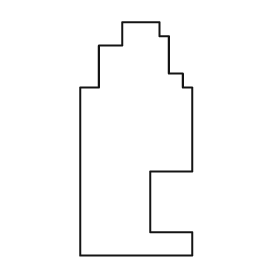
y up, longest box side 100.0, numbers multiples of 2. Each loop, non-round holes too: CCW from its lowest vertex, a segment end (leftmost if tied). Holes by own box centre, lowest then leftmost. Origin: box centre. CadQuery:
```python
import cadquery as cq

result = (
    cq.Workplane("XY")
    .moveTo(-24.0, -50.0)
    .lineTo(24.0, -50.0)
    .lineTo(24.0, -40.0)
    .lineTo(6.0, -40.0)
    .lineTo(6.0, -14.0)
    .lineTo(24.0, -14.0)
    .lineTo(24.0, 22.0)
    .lineTo(20.0, 22.0)
    .lineTo(20.0, 28.0)
    .lineTo(14.0, 28.0)
    .lineTo(14.0, 44.0)
    .lineTo(10.0, 44.0)
    .lineTo(10.0, 50.0)
    .lineTo(-6.0, 50.0)
    .lineTo(-6.0, 40.0)
    .lineTo(-16.0, 40.0)
    .lineTo(-16.0, 22.0)
    .lineTo(-24.0, 22.0)
    .close()
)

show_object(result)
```